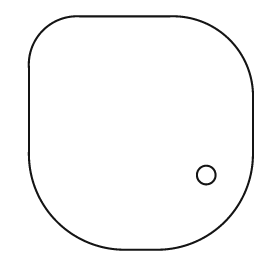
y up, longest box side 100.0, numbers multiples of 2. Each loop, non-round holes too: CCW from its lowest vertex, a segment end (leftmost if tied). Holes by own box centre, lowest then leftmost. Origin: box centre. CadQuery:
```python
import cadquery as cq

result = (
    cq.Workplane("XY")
    .moveTo(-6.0, -50.0)
    .lineTo(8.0, -50.0)
    .threePointArc((36.0, -38.0), (48.0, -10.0))
    .lineTo(48.0, 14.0)
    .threePointArc((38.0, 40.0), (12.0, 50.0))
    .lineTo(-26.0, 50.0)
    .threePointArc((-42.0, 44.0), (-48.0, 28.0))
    .lineTo(-48.0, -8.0)
    .threePointArc((-36.0, -38.0), (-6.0, -50.0))
    .close()
    .moveTo(28.0, -18.0)
    .circle(4.0)
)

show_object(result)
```